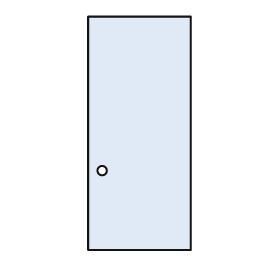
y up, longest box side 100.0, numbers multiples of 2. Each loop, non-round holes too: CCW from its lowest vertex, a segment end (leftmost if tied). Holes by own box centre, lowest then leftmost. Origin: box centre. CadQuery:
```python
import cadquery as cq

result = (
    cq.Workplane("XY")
    .moveTo(-22.0, -50.0)
    .lineTo(22.0, -50.0)
    .lineTo(22.0, 50.0)
    .lineTo(-22.0, 50.0)
    .close()
    .moveTo(-16.0, -16.0)
    .circle(2.0)
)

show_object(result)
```